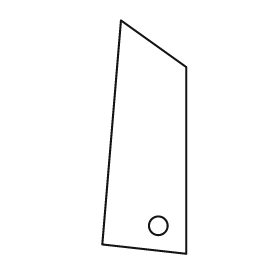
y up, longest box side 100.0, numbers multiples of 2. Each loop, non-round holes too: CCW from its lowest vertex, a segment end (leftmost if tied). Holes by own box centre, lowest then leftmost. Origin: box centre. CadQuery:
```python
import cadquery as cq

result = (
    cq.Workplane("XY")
    .moveTo(18.0, -50.0)
    .lineTo(18.0, 30.0)
    .lineTo(-10.0, 50.0)
    .lineTo(-18.0, -46.0)
    .close()
    .moveTo(6.0, -38.0)
    .circle(4.0)
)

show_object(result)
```